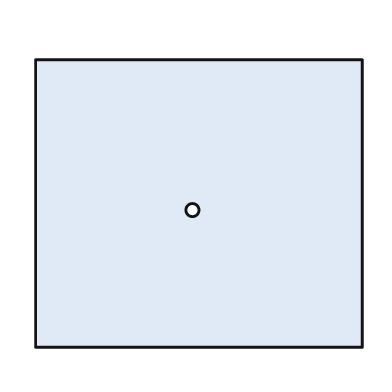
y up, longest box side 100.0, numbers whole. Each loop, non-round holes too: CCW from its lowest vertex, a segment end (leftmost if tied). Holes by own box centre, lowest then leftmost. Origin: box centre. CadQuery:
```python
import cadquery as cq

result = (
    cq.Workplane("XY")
    .moveTo(-50.0, -44.0)
    .lineTo(50.0, -44.0)
    .lineTo(50.0, 44.0)
    .lineTo(-50.0, 44.0)
    .close()
    .moveTo(-2.0, -2.0)
    .circle(2.0)
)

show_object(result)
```